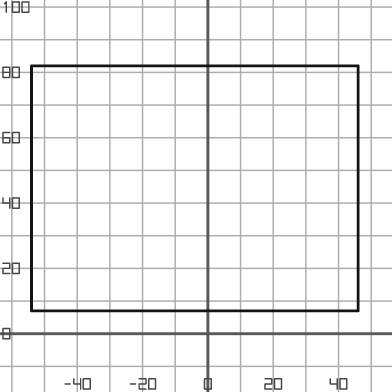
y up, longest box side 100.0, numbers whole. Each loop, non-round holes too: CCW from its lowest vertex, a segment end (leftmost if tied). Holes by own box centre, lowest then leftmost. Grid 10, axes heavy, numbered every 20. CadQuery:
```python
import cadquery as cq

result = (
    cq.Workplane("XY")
    .moveTo(-54.0, 7.0)
    .lineTo(46.0, 7.0)
    .lineTo(46.0, 82.0)
    .lineTo(-54.0, 82.0)
    .close()
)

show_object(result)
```